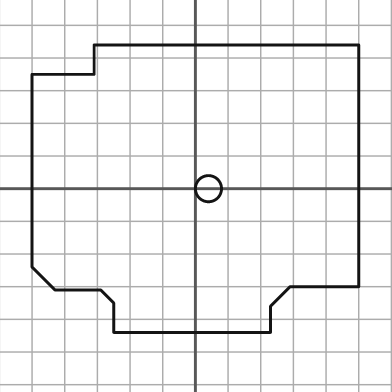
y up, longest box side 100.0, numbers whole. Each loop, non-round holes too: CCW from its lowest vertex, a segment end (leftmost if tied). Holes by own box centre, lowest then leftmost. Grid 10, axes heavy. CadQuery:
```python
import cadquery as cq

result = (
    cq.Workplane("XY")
    .moveTo(-25.0, -44.0)
    .lineTo(23.0, -44.0)
    .lineTo(23.0, -36.0)
    .lineTo(29.0, -30.0)
    .lineTo(50.0, -30.0)
    .lineTo(50.0, 44.0)
    .lineTo(-31.0, 44.0)
    .lineTo(-31.0, 35.0)
    .lineTo(-50.0, 35.0)
    .lineTo(-50.0, -24.0)
    .lineTo(-43.0, -31.0)
    .lineTo(-29.0, -31.0)
    .lineTo(-25.0, -35.0)
    .close()
    .moveTo(4.0, 0.0)
    .circle(4.0)
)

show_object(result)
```